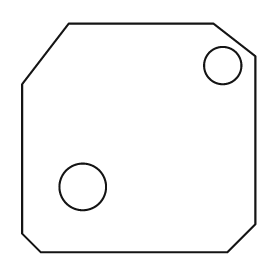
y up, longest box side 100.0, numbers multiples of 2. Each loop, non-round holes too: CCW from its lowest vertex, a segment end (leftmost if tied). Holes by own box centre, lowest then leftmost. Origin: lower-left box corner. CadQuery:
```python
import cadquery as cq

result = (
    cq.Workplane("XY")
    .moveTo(8.0, 0.0)
    .lineTo(88.0, 0.0)
    .lineTo(100.0, 12.0)
    .lineTo(100.0, 84.0)
    .lineTo(82.0, 98.0)
    .lineTo(20.0, 98.0)
    .lineTo(0.0, 72.0)
    .lineTo(0.0, 8.0)
    .close()
    .moveTo(26.0, 28.0)
    .circle(10.0)
    .moveTo(86.0, 80.0)
    .circle(8.0)
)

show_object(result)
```